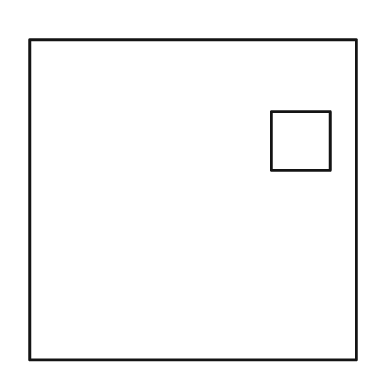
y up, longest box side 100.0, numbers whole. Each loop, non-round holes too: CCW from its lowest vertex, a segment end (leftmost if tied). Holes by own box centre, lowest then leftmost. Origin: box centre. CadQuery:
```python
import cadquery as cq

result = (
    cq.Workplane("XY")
    .moveTo(-50.0, -49.0)
    .lineTo(50.0, -49.0)
    .lineTo(50.0, 49.0)
    .lineTo(-50.0, 49.0)
    .close()
    .moveTo(24.0, 9.0)
    .lineTo(42.0, 9.0)
    .lineTo(42.0, 27.0)
    .lineTo(24.0, 27.0)
    .close()
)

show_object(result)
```